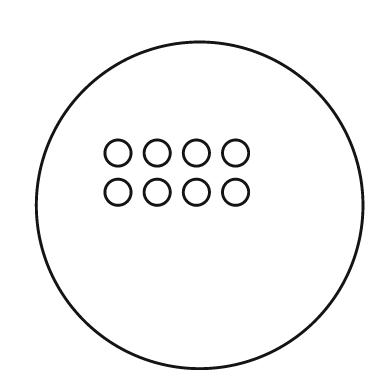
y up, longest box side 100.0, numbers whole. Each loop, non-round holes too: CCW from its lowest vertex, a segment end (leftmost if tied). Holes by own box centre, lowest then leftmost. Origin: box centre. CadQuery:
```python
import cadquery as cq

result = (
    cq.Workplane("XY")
    .moveTo(0.0, 0.0)
    .circle(50.0)
    .moveTo(-25.0, 4.0)
    .circle(4.0)
    .moveTo(-13.0, 4.0)
    .circle(4.0)
    .moveTo(-1.0, 4.0)
    .circle(4.0)
    .moveTo(11.0, 4.0)
    .circle(4.0)
    .moveTo(-25.0, 16.0)
    .circle(4.0)
    .moveTo(-13.0, 16.0)
    .circle(4.0)
    .moveTo(-1.0, 16.0)
    .circle(4.0)
    .moveTo(11.0, 16.0)
    .circle(4.0)
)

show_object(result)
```